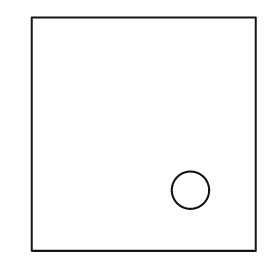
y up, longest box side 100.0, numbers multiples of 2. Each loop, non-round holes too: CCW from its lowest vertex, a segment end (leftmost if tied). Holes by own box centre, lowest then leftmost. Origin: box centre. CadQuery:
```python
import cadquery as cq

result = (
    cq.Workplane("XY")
    .moveTo(-48.0, -50.0)
    .lineTo(48.0, -50.0)
    .lineTo(48.0, 50.0)
    .lineTo(-48.0, 50.0)
    .close()
    .moveTo(20.0, -24.0)
    .circle(8.0)
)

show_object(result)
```